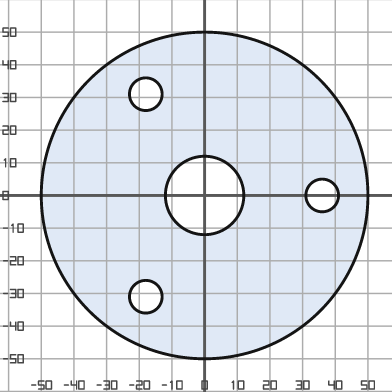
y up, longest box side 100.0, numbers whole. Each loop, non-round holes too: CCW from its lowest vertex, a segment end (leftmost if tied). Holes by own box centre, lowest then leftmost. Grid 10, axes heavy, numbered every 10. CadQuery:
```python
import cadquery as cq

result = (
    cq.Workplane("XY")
    .moveTo(0.0, 0.0)
    .circle(50.0)
    .moveTo(-18.0, -31.0)
    .circle(5.0)
    .moveTo(0.0, 0.0)
    .circle(12.0)
    .moveTo(36.0, 0.0)
    .circle(5.0)
    .moveTo(-18.0, 31.0)
    .circle(5.0)
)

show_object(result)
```